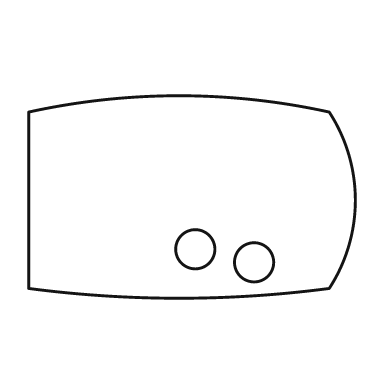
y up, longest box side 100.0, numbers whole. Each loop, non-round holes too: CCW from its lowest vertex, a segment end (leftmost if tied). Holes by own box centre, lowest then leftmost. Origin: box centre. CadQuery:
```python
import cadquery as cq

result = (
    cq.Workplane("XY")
    .moveTo(-50.0, -28.0)
    .threePointArc((-4.0, -31.0), (42.0, -28.0))
    .threePointArc((50.0, -1.0), (42.0, 26.0))
    .threePointArc((-4.0, 31.0), (-50.0, 26.0))
    .close()
    .moveTo(19.0, -20.0)
    .circle(6.0)
    .moveTo(1.0, -16.0)
    .circle(6.0)
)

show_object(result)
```